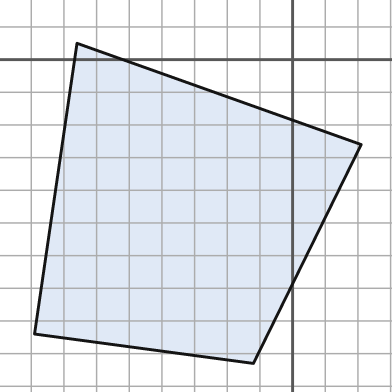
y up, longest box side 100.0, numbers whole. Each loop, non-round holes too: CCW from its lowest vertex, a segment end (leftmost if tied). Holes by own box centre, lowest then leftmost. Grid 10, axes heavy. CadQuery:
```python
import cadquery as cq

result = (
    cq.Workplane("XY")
    .moveTo(-12.0, -93.0)
    .lineTo(21.0, -26.0)
    .lineTo(-66.0, 5.0)
    .lineTo(-79.0, -84.0)
    .close()
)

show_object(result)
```